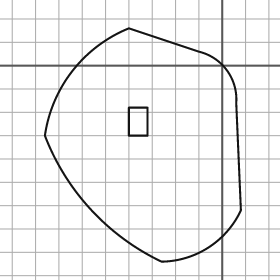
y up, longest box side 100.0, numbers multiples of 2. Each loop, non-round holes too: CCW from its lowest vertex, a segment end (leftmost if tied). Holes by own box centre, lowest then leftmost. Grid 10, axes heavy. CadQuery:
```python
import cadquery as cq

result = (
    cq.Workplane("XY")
    .moveTo(-26.0, -84.0)
    .threePointArc((-6.0, -78.0), (8.0, -62.0))
    .lineTo(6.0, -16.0)
    .threePointArc((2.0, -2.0), (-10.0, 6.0))
    .lineTo(-40.0, 16.0)
    .threePointArc((-64.0, -2.0), (-76.0, -30.0))
    .threePointArc((-56.0, -62.0), (-26.0, -84.0))
    .close()
    .moveTo(-40.0, -30.0)
    .lineTo(-32.0, -30.0)
    .lineTo(-32.0, -18.0)
    .lineTo(-40.0, -18.0)
    .close()
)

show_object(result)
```